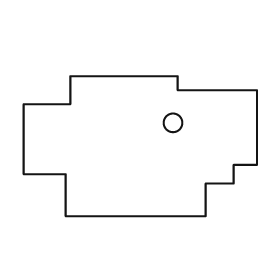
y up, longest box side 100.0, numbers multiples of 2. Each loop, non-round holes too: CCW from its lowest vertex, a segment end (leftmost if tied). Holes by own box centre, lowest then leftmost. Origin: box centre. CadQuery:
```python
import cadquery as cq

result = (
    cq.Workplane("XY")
    .moveTo(-32.0, -30.0)
    .lineTo(28.0, -30.0)
    .lineTo(28.0, -16.0)
    .lineTo(40.0, -16.0)
    .lineTo(40.0, -8.0)
    .lineTo(50.0, -8.0)
    .lineTo(50.0, 24.0)
    .lineTo(16.0, 24.0)
    .lineTo(16.0, 30.0)
    .lineTo(-30.0, 30.0)
    .lineTo(-30.0, 18.0)
    .lineTo(-50.0, 18.0)
    .lineTo(-50.0, -12.0)
    .lineTo(-32.0, -12.0)
    .close()
    .moveTo(14.0, 10.0)
    .circle(4.0)
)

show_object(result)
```